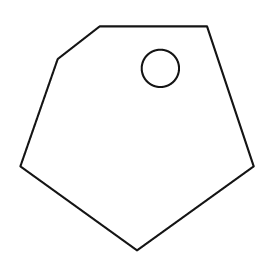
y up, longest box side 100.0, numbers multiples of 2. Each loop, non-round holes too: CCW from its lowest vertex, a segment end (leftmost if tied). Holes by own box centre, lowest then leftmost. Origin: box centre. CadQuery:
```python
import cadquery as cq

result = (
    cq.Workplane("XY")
    .moveTo(0.0, -48.0)
    .lineTo(50.0, -12.0)
    .lineTo(30.0, 48.0)
    .lineTo(-16.0, 48.0)
    .lineTo(-34.0, 34.0)
    .lineTo(-50.0, -12.0)
    .close()
    .moveTo(10.0, 30.0)
    .circle(8.0)
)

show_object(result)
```